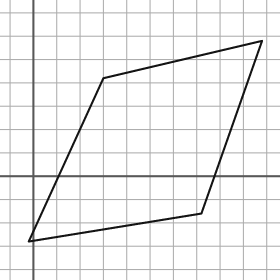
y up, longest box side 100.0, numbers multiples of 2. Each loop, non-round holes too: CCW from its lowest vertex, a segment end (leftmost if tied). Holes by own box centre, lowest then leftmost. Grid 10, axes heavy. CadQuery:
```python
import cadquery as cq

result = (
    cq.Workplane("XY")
    .moveTo(-2.0, -28.0)
    .lineTo(72.0, -16.0)
    .lineTo(98.0, 58.0)
    .lineTo(30.0, 42.0)
    .close()
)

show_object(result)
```